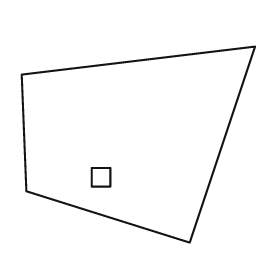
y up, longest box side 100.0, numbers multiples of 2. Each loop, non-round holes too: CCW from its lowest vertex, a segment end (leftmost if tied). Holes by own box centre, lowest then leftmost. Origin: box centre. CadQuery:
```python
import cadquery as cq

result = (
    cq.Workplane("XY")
    .moveTo(22.0, -42.0)
    .lineTo(50.0, 42.0)
    .lineTo(-50.0, 30.0)
    .lineTo(-48.0, -20.0)
    .close()
    .moveTo(-20.0, -18.0)
    .lineTo(-12.0, -18.0)
    .lineTo(-12.0, -10.0)
    .lineTo(-20.0, -10.0)
    .close()
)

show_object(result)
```